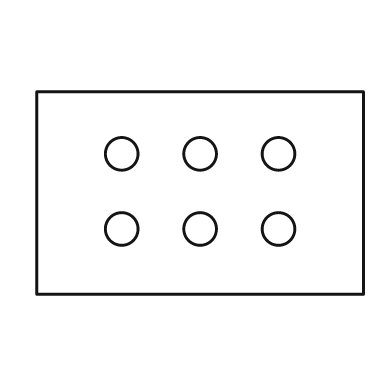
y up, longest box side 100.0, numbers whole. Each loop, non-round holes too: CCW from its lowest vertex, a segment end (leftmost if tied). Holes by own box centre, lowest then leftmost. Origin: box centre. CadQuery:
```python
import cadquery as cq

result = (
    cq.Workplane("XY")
    .moveTo(-50.0, -31.0)
    .lineTo(50.0, -31.0)
    .lineTo(50.0, 31.0)
    .lineTo(-50.0, 31.0)
    .close()
    .moveTo(-24.0, -11.0)
    .circle(5.0)
    .moveTo(0.0, -11.0)
    .circle(5.0)
    .moveTo(24.0, -11.0)
    .circle(5.0)
    .moveTo(-24.0, 12.0)
    .circle(5.0)
    .moveTo(0.0, 12.0)
    .circle(5.0)
    .moveTo(24.0, 12.0)
    .circle(5.0)
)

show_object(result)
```